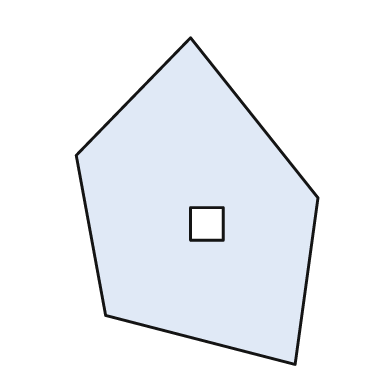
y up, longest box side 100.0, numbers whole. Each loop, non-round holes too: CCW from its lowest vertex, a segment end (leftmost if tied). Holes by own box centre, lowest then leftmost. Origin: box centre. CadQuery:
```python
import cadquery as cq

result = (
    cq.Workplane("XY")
    .moveTo(30.0, -50.0)
    .lineTo(37.0, 1.0)
    .lineTo(-2.0, 50.0)
    .lineTo(-37.0, 14.0)
    .lineTo(-28.0, -35.0)
    .close()
    .moveTo(-2.0, -12.0)
    .lineTo(8.0, -12.0)
    .lineTo(8.0, -2.0)
    .lineTo(-2.0, -2.0)
    .close()
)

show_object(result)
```